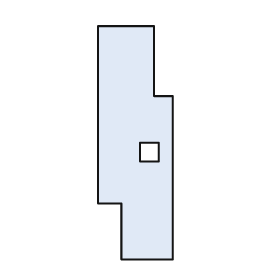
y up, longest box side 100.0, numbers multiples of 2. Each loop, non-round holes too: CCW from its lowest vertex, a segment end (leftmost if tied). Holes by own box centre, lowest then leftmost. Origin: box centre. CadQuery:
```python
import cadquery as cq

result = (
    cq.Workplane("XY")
    .moveTo(-6.0, -50.0)
    .lineTo(16.0, -50.0)
    .lineTo(16.0, 20.0)
    .lineTo(8.0, 20.0)
    .lineTo(8.0, 50.0)
    .lineTo(-16.0, 50.0)
    .lineTo(-16.0, -26.0)
    .lineTo(-6.0, -26.0)
    .close()
    .moveTo(2.0, -8.0)
    .lineTo(10.0, -8.0)
    .lineTo(10.0, 0.0)
    .lineTo(2.0, 0.0)
    .close()
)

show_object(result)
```